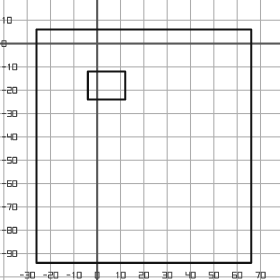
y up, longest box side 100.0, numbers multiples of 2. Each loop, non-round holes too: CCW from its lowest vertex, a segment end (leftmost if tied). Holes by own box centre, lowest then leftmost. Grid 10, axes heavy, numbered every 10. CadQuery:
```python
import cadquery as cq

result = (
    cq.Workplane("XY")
    .moveTo(-26.0, -94.0)
    .lineTo(66.0, -94.0)
    .lineTo(66.0, 6.0)
    .lineTo(-26.0, 6.0)
    .close()
    .moveTo(-4.0, -24.0)
    .lineTo(12.0, -24.0)
    .lineTo(12.0, -12.0)
    .lineTo(-4.0, -12.0)
    .close()
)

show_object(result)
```